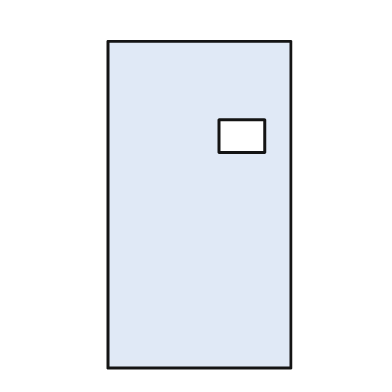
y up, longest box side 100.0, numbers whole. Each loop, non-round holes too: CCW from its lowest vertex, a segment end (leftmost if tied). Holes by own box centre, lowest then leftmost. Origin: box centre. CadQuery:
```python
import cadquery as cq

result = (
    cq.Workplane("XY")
    .moveTo(-28.0, -50.0)
    .lineTo(28.0, -50.0)
    .lineTo(28.0, 50.0)
    .lineTo(-28.0, 50.0)
    .close()
    .moveTo(6.0, 16.0)
    .lineTo(20.0, 16.0)
    .lineTo(20.0, 26.0)
    .lineTo(6.0, 26.0)
    .close()
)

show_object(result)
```